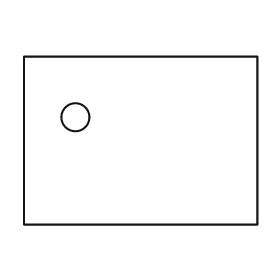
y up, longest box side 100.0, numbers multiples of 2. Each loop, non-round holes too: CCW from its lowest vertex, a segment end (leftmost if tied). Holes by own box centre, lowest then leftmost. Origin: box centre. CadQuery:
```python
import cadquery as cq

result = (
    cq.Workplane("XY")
    .moveTo(-50.0, -36.0)
    .lineTo(50.0, -36.0)
    .lineTo(50.0, 36.0)
    .lineTo(-50.0, 36.0)
    .close()
    .moveTo(-28.0, 10.0)
    .circle(6.0)
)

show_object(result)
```